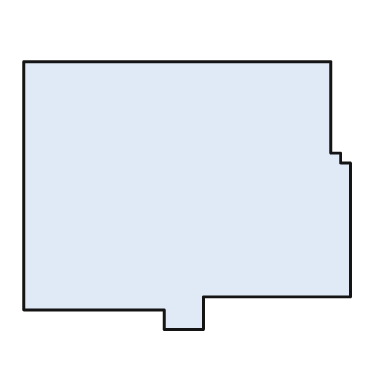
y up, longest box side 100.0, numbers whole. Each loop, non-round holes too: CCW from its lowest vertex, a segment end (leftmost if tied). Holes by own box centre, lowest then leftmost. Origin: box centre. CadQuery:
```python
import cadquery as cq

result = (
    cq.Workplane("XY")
    .moveTo(-7.0, -41.0)
    .lineTo(5.0, -41.0)
    .lineTo(5.0, -31.0)
    .lineTo(50.0, -31.0)
    .lineTo(50.0, 10.0)
    .lineTo(47.0, 10.0)
    .lineTo(47.0, 13.0)
    .lineTo(44.0, 13.0)
    .lineTo(44.0, 41.0)
    .lineTo(-50.0, 41.0)
    .lineTo(-50.0, -35.0)
    .lineTo(-7.0, -35.0)
    .close()
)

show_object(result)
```